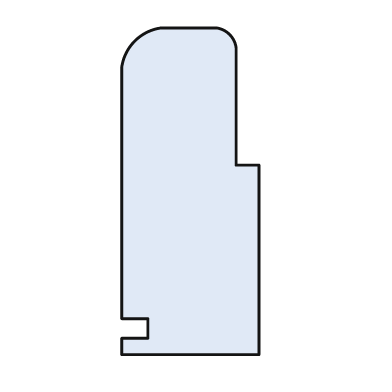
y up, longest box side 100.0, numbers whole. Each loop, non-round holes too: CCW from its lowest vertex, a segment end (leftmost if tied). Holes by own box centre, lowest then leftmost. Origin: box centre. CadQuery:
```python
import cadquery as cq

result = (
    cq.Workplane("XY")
    .moveTo(-21.0, -50.0)
    .lineTo(21.0, -50.0)
    .lineTo(21.0, 8.0)
    .lineTo(14.0, 8.0)
    .lineTo(14.0, 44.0)
    .threePointArc((12.0, 48.0), (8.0, 50.0))
    .lineTo(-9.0, 50.0)
    .threePointArc((-17.0, 46.0), (-21.0, 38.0))
    .lineTo(-21.0, -39.0)
    .lineTo(-13.0, -39.0)
    .lineTo(-13.0, -45.0)
    .lineTo(-21.0, -45.0)
    .close()
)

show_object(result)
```